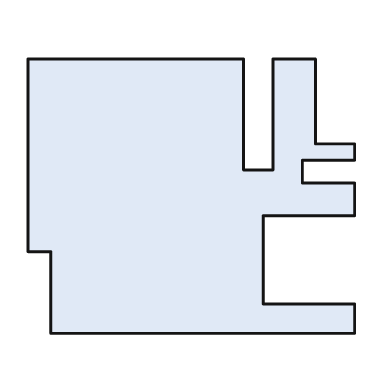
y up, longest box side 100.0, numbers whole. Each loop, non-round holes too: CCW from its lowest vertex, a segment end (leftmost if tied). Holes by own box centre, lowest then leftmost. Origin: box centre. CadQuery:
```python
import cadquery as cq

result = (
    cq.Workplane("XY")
    .moveTo(-43.0, -42.0)
    .lineTo(50.0, -42.0)
    .lineTo(50.0, -33.0)
    .lineTo(22.0, -33.0)
    .lineTo(22.0, -6.0)
    .lineTo(50.0, -6.0)
    .lineTo(50.0, 4.0)
    .lineTo(34.0, 4.0)
    .lineTo(34.0, 11.0)
    .lineTo(50.0, 11.0)
    .lineTo(50.0, 16.0)
    .lineTo(38.0, 16.0)
    .lineTo(38.0, 42.0)
    .lineTo(25.0, 42.0)
    .lineTo(25.0, 8.0)
    .lineTo(16.0, 8.0)
    .lineTo(16.0, 42.0)
    .lineTo(-50.0, 42.0)
    .lineTo(-50.0, -17.0)
    .lineTo(-43.0, -17.0)
    .close()
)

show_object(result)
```